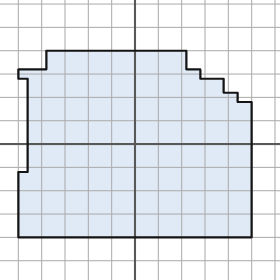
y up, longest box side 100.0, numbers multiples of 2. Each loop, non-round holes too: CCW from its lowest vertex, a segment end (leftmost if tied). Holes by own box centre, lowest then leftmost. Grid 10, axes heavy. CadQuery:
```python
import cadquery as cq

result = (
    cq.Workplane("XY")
    .moveTo(-50.0, -40.0)
    .lineTo(50.0, -40.0)
    .lineTo(50.0, 18.0)
    .lineTo(44.0, 18.0)
    .lineTo(44.0, 22.0)
    .lineTo(38.0, 22.0)
    .lineTo(38.0, 28.0)
    .lineTo(28.0, 28.0)
    .lineTo(28.0, 32.0)
    .lineTo(22.0, 32.0)
    .lineTo(22.0, 40.0)
    .lineTo(-38.0, 40.0)
    .lineTo(-38.0, 32.0)
    .lineTo(-50.0, 32.0)
    .lineTo(-50.0, 28.0)
    .lineTo(-46.0, 28.0)
    .lineTo(-46.0, -12.0)
    .lineTo(-50.0, -12.0)
    .close()
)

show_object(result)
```